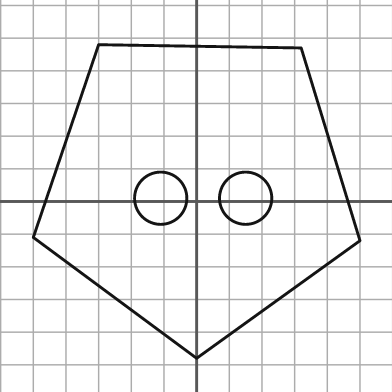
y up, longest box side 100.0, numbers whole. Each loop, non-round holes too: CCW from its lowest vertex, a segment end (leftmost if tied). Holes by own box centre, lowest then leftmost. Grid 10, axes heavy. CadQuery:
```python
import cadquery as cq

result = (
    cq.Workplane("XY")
    .moveTo(0.0, -48.0)
    .lineTo(50.0, -12.0)
    .lineTo(32.0, 47.0)
    .lineTo(-30.0, 48.0)
    .lineTo(-50.0, -11.0)
    .close()
    .moveTo(-11.0, 1.0)
    .circle(8.0)
    .moveTo(15.0, 1.0)
    .circle(8.0)
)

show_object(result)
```